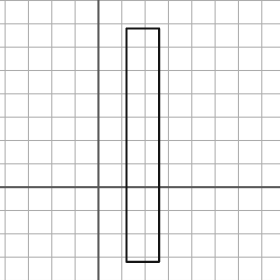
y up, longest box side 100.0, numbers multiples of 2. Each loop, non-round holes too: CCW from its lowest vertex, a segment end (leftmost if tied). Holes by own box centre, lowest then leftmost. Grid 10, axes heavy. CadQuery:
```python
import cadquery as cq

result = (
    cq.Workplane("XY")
    .moveTo(12.0, -32.0)
    .lineTo(26.0, -32.0)
    .lineTo(26.0, 68.0)
    .lineTo(12.0, 68.0)
    .close()
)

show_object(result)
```